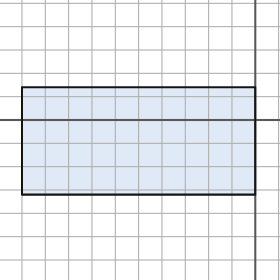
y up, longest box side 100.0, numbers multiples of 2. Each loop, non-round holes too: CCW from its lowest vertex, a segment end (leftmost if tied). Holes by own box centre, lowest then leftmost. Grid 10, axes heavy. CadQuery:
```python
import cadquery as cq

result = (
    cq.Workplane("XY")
    .moveTo(-100.0, -32.0)
    .lineTo(0.0, -32.0)
    .lineTo(0.0, 14.0)
    .lineTo(-100.0, 14.0)
    .close()
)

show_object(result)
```